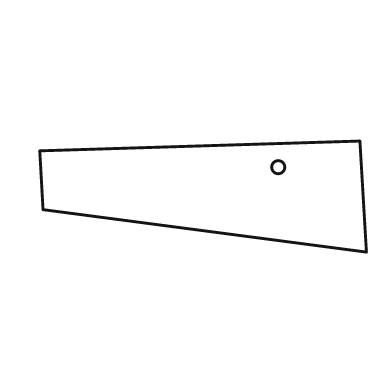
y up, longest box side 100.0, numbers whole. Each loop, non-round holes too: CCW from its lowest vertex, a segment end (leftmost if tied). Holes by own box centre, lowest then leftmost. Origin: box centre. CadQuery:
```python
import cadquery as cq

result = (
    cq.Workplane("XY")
    .moveTo(50.0, -17.0)
    .lineTo(48.0, 17.0)
    .lineTo(-50.0, 14.0)
    .lineTo(-49.0, -4.0)
    .close()
    .moveTo(23.0, 9.0)
    .circle(2.0)
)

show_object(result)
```